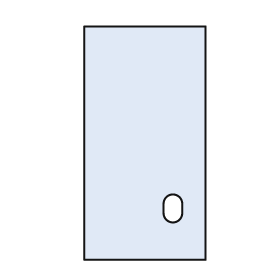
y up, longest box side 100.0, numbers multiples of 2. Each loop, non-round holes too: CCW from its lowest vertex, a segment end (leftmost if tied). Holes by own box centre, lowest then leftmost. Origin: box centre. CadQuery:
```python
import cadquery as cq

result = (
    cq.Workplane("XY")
    .moveTo(-26.0, -50.0)
    .lineTo(26.0, -50.0)
    .lineTo(26.0, 50.0)
    .lineTo(-26.0, 50.0)
    .close()
    .moveTo(8.0, -30.0)
    .threePointArc((12.0, -34.0), (16.0, -30.0))
    .lineTo(16.0, -26.0)
    .threePointArc((12.0, -22.0), (8.0, -26.0))
    .close()
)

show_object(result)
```